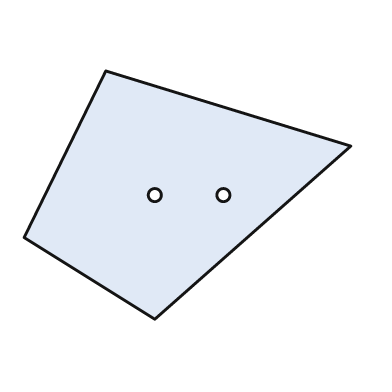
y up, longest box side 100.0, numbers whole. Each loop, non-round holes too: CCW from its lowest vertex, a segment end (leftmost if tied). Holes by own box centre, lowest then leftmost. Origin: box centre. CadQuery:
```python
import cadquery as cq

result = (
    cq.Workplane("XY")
    .moveTo(-10.0, -38.0)
    .lineTo(50.0, 15.0)
    .lineTo(-25.0, 38.0)
    .lineTo(-50.0, -13.0)
    .close()
    .moveTo(-10.0, 0.0)
    .circle(2.0)
    .moveTo(11.0, 0.0)
    .circle(2.0)
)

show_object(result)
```